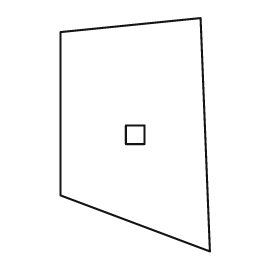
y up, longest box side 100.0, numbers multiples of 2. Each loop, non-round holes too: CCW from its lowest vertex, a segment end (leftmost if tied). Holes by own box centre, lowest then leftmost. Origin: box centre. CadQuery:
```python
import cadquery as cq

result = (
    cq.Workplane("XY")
    .moveTo(32.0, -50.0)
    .lineTo(28.0, 50.0)
    .lineTo(-32.0, 44.0)
    .lineTo(-32.0, -26.0)
    .close()
    .moveTo(-4.0, -4.0)
    .lineTo(4.0, -4.0)
    .lineTo(4.0, 4.0)
    .lineTo(-4.0, 4.0)
    .close()
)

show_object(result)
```